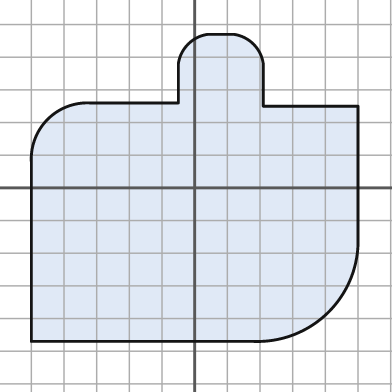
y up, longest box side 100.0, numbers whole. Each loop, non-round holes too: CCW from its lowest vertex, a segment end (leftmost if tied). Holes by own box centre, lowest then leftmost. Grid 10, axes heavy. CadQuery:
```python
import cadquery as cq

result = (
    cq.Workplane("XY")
    .moveTo(-50.0, -47.0)
    .lineTo(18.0, -47.0)
    .threePointArc((41.0, -38.0), (50.0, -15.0))
    .lineTo(50.0, 25.0)
    .lineTo(21.0, 25.0)
    .lineTo(21.0, 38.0)
    .threePointArc((18.0, 44.0), (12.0, 47.0))
    .lineTo(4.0, 47.0)
    .threePointArc((-2.0, 44.0), (-5.0, 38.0))
    .lineTo(-5.0, 26.0)
    .lineTo(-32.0, 26.0)
    .threePointArc((-45.0, 21.0), (-50.0, 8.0))
    .close()
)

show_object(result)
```